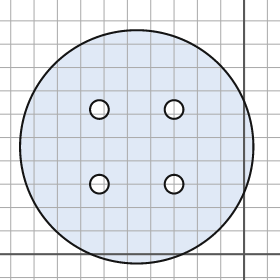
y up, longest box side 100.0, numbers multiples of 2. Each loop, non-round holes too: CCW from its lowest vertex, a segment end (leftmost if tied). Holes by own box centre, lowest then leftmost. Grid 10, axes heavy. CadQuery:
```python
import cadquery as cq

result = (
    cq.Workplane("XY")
    .moveTo(-46.0, 46.0)
    .circle(50.0)
    .moveTo(-62.0, 30.0)
    .circle(4.0)
    .moveTo(-30.0, 30.0)
    .circle(4.0)
    .moveTo(-62.0, 62.0)
    .circle(4.0)
    .moveTo(-30.0, 62.0)
    .circle(4.0)
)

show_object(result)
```